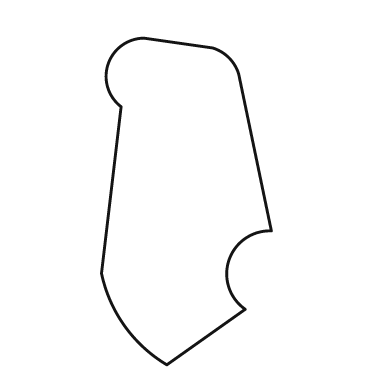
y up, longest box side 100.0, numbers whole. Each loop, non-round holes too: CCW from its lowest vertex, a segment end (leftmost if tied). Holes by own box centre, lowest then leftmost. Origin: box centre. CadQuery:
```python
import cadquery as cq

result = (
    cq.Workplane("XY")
    .moveTo(-6.0, -50.0)
    .lineTo(18.0, -33.0)
    .threePointArc((13.0, -18.0), (26.0, -9.0))
    .lineTo(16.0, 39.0)
    .threePointArc((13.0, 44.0), (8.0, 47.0))
    .lineTo(-13.0, 50.0)
    .threePointArc((-24.0, 42.0), (-20.0, 29.0))
    .lineTo(-26.0, -22.0)
    .threePointArc((-19.0, -38.0), (-6.0, -50.0))
    .close()
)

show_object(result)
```